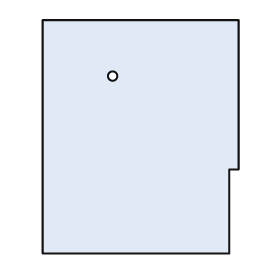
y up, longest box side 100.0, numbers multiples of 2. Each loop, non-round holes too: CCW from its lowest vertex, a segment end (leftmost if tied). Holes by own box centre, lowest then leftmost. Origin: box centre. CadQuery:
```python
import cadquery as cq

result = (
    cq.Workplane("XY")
    .moveTo(-42.0, -50.0)
    .lineTo(38.0, -50.0)
    .lineTo(38.0, -14.0)
    .lineTo(42.0, -14.0)
    .lineTo(42.0, 50.0)
    .lineTo(-42.0, 50.0)
    .close()
    .moveTo(-12.0, 26.0)
    .circle(2.0)
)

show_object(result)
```